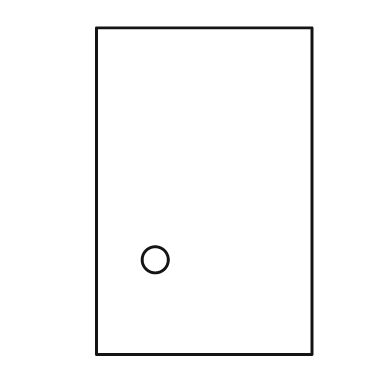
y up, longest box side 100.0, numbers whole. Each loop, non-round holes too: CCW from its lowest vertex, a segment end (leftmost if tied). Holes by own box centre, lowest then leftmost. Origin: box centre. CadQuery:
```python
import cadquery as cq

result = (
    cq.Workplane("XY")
    .moveTo(-33.0, -50.0)
    .lineTo(33.0, -50.0)
    .lineTo(33.0, 50.0)
    .lineTo(-33.0, 50.0)
    .close()
    .moveTo(-15.0, -21.0)
    .circle(4.0)
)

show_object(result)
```